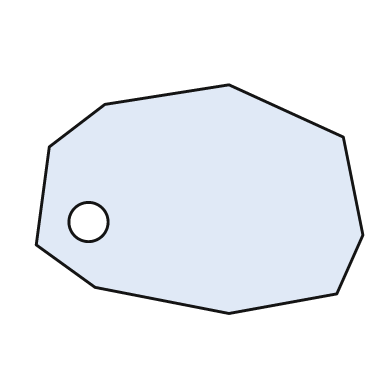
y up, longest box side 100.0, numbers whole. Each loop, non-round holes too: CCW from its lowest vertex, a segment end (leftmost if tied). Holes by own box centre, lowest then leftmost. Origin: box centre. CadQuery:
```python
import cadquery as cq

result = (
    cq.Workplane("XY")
    .moveTo(9.0, -35.0)
    .lineTo(42.0, -29.0)
    .lineTo(50.0, -11.0)
    .lineTo(44.0, 19.0)
    .lineTo(9.0, 35.0)
    .lineTo(-29.0, 29.0)
    .lineTo(-46.0, 16.0)
    .lineTo(-50.0, -14.0)
    .lineTo(-32.0, -27.0)
    .close()
    .moveTo(-34.0, -7.0)
    .circle(6.0)
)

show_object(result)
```